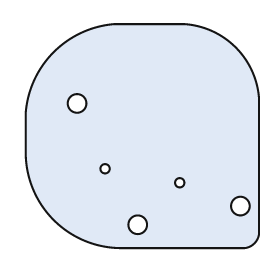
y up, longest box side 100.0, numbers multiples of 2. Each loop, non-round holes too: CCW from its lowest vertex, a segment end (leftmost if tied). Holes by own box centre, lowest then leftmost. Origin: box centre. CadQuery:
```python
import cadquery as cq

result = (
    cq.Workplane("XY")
    .moveTo(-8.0, -48.0)
    .lineTo(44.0, -48.0)
    .threePointArc((48.0, -46.0), (50.0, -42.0))
    .lineTo(50.0, 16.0)
    .threePointArc((40.0, 38.0), (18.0, 48.0))
    .lineTo(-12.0, 48.0)
    .threePointArc((-38.0, 36.0), (-50.0, 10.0))
    .lineTo(-50.0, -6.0)
    .threePointArc((-38.0, -36.0), (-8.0, -48.0))
    .close()
    .moveTo(-2.0, -38.0)
    .circle(4.0)
    .moveTo(42.0, -30.0)
    .circle(4.0)
    .moveTo(16.0, -20.0)
    .circle(2.0)
    .moveTo(-16.0, -14.0)
    .circle(2.0)
    .moveTo(-28.0, 14.0)
    .circle(4.0)
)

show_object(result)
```